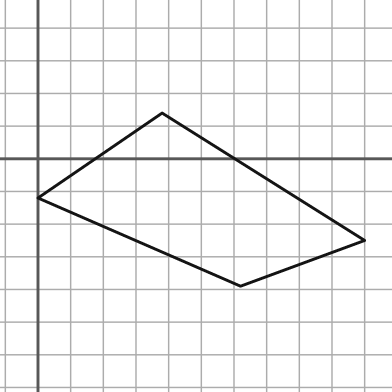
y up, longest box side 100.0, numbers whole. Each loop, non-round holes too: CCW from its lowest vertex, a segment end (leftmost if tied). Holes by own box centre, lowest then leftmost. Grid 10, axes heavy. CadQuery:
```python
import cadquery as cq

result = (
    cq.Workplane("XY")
    .moveTo(62.0, -39.0)
    .lineTo(100.0, -25.0)
    .lineTo(38.0, 14.0)
    .lineTo(0.0, -12.0)
    .close()
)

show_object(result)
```